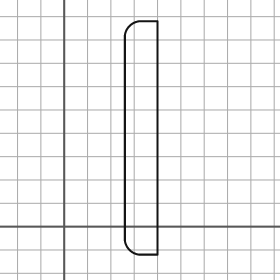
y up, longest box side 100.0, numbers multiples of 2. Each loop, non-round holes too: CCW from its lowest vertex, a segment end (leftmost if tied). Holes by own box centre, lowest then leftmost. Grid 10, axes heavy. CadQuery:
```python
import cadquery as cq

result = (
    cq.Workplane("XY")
    .moveTo(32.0, -12.0)
    .lineTo(40.0, -12.0)
    .lineTo(40.0, 88.0)
    .lineTo(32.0, 88.0)
    .threePointArc((28.0, 86.0), (26.0, 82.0))
    .lineTo(26.0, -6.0)
    .threePointArc((28.0, -10.0), (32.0, -12.0))
    .close()
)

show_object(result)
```